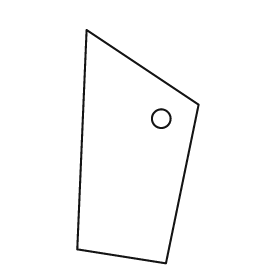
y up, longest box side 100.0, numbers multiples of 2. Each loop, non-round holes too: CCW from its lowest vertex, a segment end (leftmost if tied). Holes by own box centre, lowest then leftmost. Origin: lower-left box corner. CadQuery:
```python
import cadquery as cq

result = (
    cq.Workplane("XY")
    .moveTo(38.0, 0.0)
    .lineTo(52.0, 68.0)
    .lineTo(4.0, 100.0)
    .lineTo(0.0, 6.0)
    .close()
    .moveTo(36.0, 62.0)
    .circle(4.0)
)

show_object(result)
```